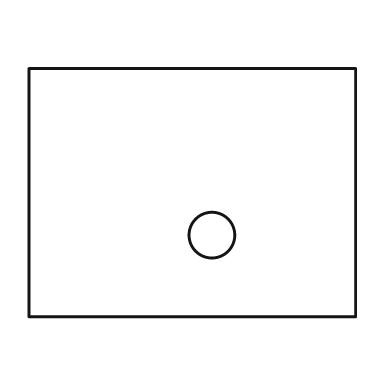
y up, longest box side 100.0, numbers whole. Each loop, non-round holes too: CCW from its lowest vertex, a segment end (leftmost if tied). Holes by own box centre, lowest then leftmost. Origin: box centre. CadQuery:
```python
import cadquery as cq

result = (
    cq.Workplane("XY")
    .moveTo(-50.0, -38.0)
    .lineTo(50.0, -38.0)
    .lineTo(50.0, 38.0)
    .lineTo(-50.0, 38.0)
    .close()
    .moveTo(6.0, -13.0)
    .circle(7.0)
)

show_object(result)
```